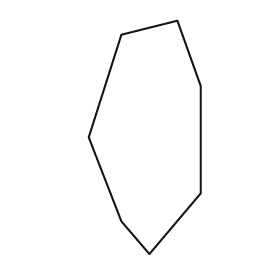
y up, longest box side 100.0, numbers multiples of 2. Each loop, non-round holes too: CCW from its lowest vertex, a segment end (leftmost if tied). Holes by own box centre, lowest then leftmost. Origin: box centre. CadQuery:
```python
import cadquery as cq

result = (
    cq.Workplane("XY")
    .moveTo(2.0, -50.0)
    .lineTo(24.0, -24.0)
    .lineTo(24.0, 22.0)
    .lineTo(14.0, 50.0)
    .lineTo(-10.0, 44.0)
    .lineTo(-24.0, 0.0)
    .lineTo(-10.0, -36.0)
    .close()
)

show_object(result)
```